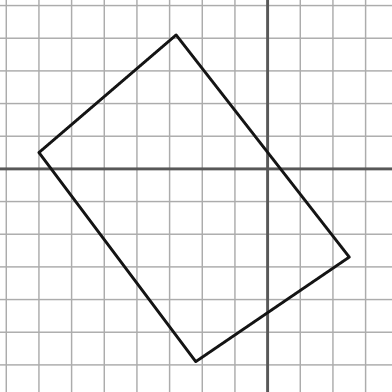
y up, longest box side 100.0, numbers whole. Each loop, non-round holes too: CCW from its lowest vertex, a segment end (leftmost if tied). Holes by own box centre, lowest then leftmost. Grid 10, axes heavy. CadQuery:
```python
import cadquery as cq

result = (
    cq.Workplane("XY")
    .moveTo(-22.0, -59.0)
    .lineTo(25.0, -27.0)
    .lineTo(-28.0, 41.0)
    .lineTo(-70.0, 5.0)
    .close()
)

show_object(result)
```